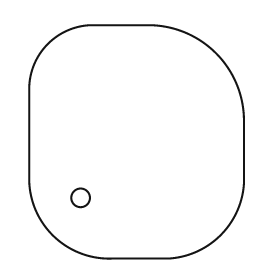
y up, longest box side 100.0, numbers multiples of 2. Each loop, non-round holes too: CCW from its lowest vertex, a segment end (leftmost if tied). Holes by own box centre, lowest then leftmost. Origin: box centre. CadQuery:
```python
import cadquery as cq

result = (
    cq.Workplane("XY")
    .moveTo(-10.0, -50.0)
    .lineTo(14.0, -50.0)
    .threePointArc((36.0, -40.0), (46.0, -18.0))
    .lineTo(46.0, 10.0)
    .threePointArc((34.0, 38.0), (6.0, 50.0))
    .lineTo(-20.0, 50.0)
    .threePointArc((-38.0, 42.0), (-46.0, 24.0))
    .lineTo(-46.0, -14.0)
    .threePointArc((-36.0, -40.0), (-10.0, -50.0))
    .close()
    .moveTo(-24.0, -24.0)
    .circle(4.0)
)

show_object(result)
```